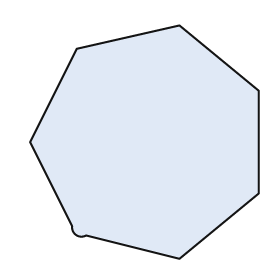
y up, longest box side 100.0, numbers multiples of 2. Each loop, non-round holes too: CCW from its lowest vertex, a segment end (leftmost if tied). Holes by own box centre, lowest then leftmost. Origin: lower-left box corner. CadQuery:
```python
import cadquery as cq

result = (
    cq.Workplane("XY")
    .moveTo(64.0, 0.0)
    .lineTo(98.0, 28.0)
    .lineTo(98.0, 72.0)
    .lineTo(64.0, 100.0)
    .lineTo(20.0, 90.0)
    .lineTo(0.0, 50.0)
    .lineTo(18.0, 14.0)
    .threePointArc((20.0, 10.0), (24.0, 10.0))
    .close()
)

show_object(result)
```